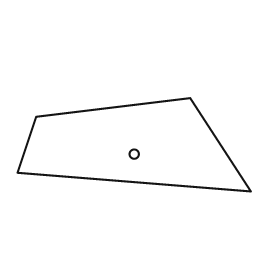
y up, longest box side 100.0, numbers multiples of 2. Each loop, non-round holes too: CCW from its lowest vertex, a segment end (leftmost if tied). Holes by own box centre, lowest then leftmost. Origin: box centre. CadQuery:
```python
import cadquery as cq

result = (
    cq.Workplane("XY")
    .moveTo(50.0, -20.0)
    .lineTo(24.0, 20.0)
    .lineTo(-42.0, 12.0)
    .lineTo(-50.0, -12.0)
    .close()
    .moveTo(0.0, -4.0)
    .circle(2.0)
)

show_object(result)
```